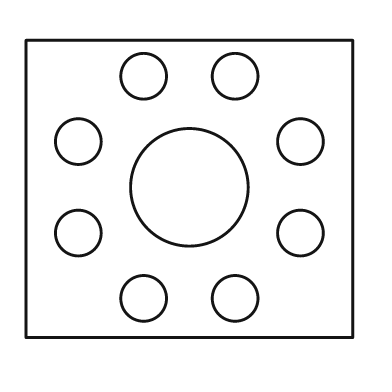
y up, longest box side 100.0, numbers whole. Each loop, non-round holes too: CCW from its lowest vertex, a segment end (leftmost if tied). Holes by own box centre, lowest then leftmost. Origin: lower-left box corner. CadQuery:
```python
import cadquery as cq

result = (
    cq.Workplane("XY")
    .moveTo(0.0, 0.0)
    .lineTo(100.0, 0.0)
    .lineTo(100.0, 91.0)
    .lineTo(0.0, 91.0)
    .close()
    .moveTo(36.0, 12.0)
    .circle(7.0)
    .moveTo(64.0, 12.0)
    .circle(7.0)
    .moveTo(16.0, 32.0)
    .circle(7.0)
    .moveTo(84.0, 32.0)
    .circle(7.0)
    .moveTo(50.0, 46.0)
    .circle(18.0)
    .moveTo(16.0, 60.0)
    .circle(7.0)
    .moveTo(84.0, 60.0)
    .circle(7.0)
    .moveTo(36.0, 80.0)
    .circle(7.0)
    .moveTo(64.0, 80.0)
    .circle(7.0)
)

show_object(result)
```